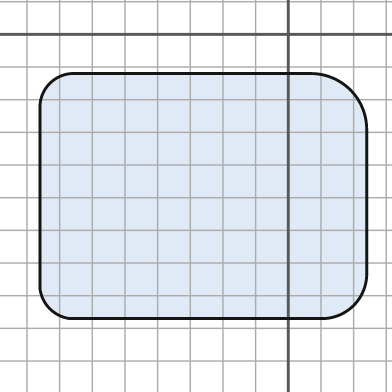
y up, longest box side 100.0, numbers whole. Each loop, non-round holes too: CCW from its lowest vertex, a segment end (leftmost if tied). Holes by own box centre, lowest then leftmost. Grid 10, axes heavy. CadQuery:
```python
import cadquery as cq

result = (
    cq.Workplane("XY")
    .moveTo(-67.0, -87.0)
    .lineTo(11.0, -87.0)
    .threePointArc((20.0, -83.0), (24.0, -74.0))
    .lineTo(24.0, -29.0)
    .threePointArc((19.0, -17.0), (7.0, -12.0))
    .lineTo(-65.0, -12.0)
    .threePointArc((-73.0, -15.0), (-76.0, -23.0))
    .lineTo(-76.0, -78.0)
    .threePointArc((-73.0, -84.0), (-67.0, -87.0))
    .close()
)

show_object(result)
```